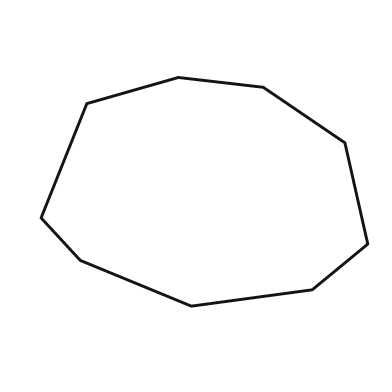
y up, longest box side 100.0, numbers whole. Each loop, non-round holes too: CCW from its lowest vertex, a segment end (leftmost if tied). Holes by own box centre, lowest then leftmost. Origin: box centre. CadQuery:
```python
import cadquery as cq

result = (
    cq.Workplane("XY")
    .moveTo(-4.0, -35.0)
    .lineTo(33.0, -30.0)
    .lineTo(50.0, -16.0)
    .lineTo(43.0, 15.0)
    .lineTo(18.0, 32.0)
    .lineTo(-8.0, 35.0)
    .lineTo(-36.0, 27.0)
    .lineTo(-50.0, -8.0)
    .lineTo(-38.0, -21.0)
    .close()
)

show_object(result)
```